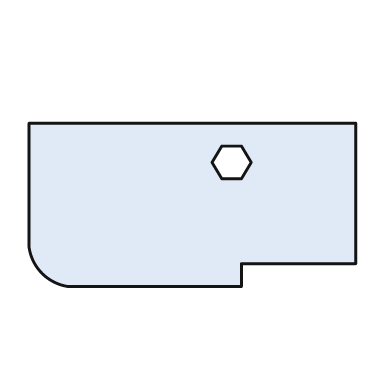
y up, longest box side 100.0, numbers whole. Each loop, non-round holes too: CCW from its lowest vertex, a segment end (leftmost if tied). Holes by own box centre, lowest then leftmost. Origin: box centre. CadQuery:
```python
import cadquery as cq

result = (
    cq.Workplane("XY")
    .moveTo(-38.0, -25.0)
    .lineTo(15.0, -25.0)
    .lineTo(15.0, -18.0)
    .lineTo(50.0, -18.0)
    .lineTo(50.0, 25.0)
    .lineTo(-50.0, 25.0)
    .lineTo(-50.0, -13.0)
    .threePointArc((-46.0, -21.0), (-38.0, -25.0))
    .close()
    .moveTo(9.0, 8.0)
    .lineTo(15.0, 8.0)
    .lineTo(18.0, 13.0)
    .lineTo(15.0, 18.0)
    .lineTo(9.0, 18.0)
    .lineTo(6.0, 13.0)
    .close()
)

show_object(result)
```